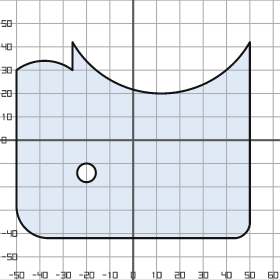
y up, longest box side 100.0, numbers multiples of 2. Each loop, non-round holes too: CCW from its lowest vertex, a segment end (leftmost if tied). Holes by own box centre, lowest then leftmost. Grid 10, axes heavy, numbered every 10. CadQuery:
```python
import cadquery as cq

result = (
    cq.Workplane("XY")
    .moveTo(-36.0, -42.0)
    .lineTo(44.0, -42.0)
    .threePointArc((48.0, -40.0), (50.0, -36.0))
    .lineTo(50.0, 42.0)
    .threePointArc((12.0, 20.0), (-26.0, 42.0))
    .lineTo(-26.0, 30.0)
    .threePointArc((-38.0, 34.0), (-50.0, 30.0))
    .lineTo(-50.0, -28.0)
    .threePointArc((-46.0, -38.0), (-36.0, -42.0))
    .close()
    .moveTo(-20.0, -14.0)
    .circle(4.0)
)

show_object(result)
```